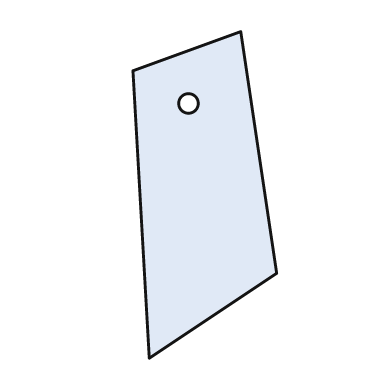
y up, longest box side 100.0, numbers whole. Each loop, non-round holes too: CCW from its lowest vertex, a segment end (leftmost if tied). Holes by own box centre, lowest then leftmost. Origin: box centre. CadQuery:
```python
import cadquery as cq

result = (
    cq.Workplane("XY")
    .moveTo(-17.0, -50.0)
    .lineTo(22.0, -24.0)
    .lineTo(11.0, 50.0)
    .lineTo(-22.0, 38.0)
    .close()
    .moveTo(-5.0, 28.0)
    .circle(3.0)
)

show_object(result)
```